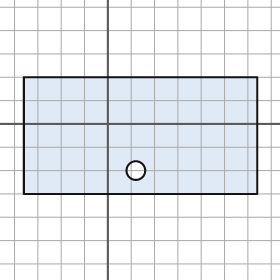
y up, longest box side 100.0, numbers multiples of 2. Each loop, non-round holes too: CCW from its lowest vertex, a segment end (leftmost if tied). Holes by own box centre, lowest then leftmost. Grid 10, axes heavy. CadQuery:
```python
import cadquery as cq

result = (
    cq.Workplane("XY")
    .moveTo(-36.0, -30.0)
    .lineTo(64.0, -30.0)
    .lineTo(64.0, 20.0)
    .lineTo(-36.0, 20.0)
    .close()
    .moveTo(12.0, -20.0)
    .circle(4.0)
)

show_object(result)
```